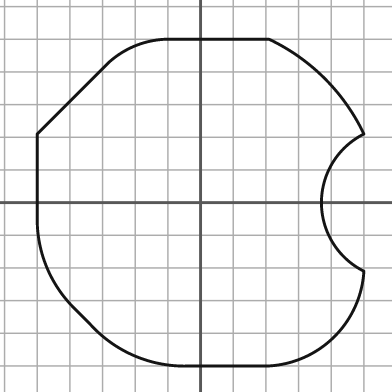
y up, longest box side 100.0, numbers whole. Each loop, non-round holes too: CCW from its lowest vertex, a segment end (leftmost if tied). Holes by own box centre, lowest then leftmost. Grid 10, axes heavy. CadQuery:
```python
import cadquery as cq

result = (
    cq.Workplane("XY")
    .moveTo(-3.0, -50.0)
    .lineTo(21.0, -50.0)
    .threePointArc((41.0, -41.0), (50.0, -21.0))
    .threePointArc((37.0, 0.0), (50.0, 21.0))
    .threePointArc((38.0, 38.0), (21.0, 50.0))
    .lineTo(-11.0, 50.0)
    .threePointArc((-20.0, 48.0), (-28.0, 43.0))
    .lineTo(-50.0, 21.0)
    .lineTo(-50.0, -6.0)
    .threePointArc((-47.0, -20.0), (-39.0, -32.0))
    .lineTo(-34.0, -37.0)
    .threePointArc((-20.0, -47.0), (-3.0, -50.0))
    .close()
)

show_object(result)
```